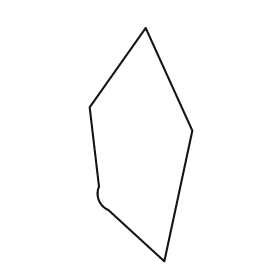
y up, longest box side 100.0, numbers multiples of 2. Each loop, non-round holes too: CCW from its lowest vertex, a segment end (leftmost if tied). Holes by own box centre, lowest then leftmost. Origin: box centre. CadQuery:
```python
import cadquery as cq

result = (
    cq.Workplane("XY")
    .moveTo(10.0, -50.0)
    .lineTo(22.0, 6.0)
    .lineTo(2.0, 50.0)
    .lineTo(-22.0, 16.0)
    .lineTo(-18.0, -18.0)
    .threePointArc((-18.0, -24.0), (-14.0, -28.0))
    .close()
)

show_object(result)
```